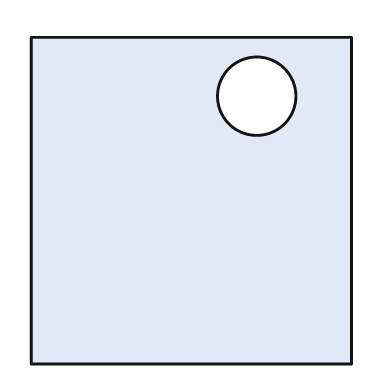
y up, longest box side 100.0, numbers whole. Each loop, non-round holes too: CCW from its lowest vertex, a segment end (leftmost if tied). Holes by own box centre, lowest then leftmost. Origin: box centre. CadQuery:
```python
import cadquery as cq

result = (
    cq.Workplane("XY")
    .moveTo(-49.0, -50.0)
    .lineTo(49.0, -50.0)
    .lineTo(49.0, 50.0)
    .lineTo(-49.0, 50.0)
    .close()
    .moveTo(20.0, 32.0)
    .circle(12.0)
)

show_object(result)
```